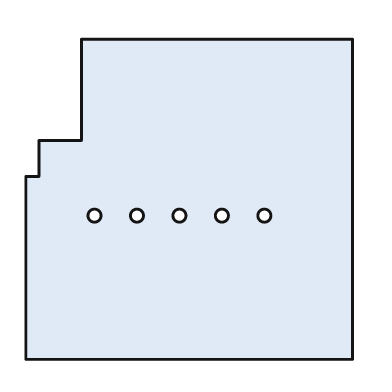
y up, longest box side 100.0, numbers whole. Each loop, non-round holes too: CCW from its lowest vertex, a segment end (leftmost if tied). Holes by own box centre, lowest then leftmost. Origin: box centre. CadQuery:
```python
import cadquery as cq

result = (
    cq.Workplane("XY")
    .moveTo(-50.0, -49.0)
    .lineTo(50.0, -49.0)
    .lineTo(50.0, 49.0)
    .lineTo(-33.0, 49.0)
    .lineTo(-33.0, 18.0)
    .lineTo(-46.0, 18.0)
    .lineTo(-46.0, 7.0)
    .lineTo(-50.0, 7.0)
    .close()
    .moveTo(-29.0, -5.0)
    .circle(2.0)
    .moveTo(-16.0, -5.0)
    .circle(2.0)
    .moveTo(-3.0, -5.0)
    .circle(2.0)
    .moveTo(10.0, -5.0)
    .circle(2.0)
    .moveTo(23.0, -5.0)
    .circle(2.0)
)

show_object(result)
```